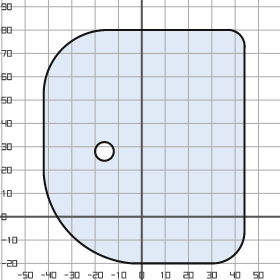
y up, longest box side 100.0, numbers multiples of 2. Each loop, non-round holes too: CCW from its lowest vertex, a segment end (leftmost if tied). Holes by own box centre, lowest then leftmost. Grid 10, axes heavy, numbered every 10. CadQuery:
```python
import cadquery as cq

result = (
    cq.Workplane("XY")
    .moveTo(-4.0, -20.0)
    .lineTo(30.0, -20.0)
    .threePointArc((40.0, -16.0), (44.0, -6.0))
    .lineTo(44.0, 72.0)
    .threePointArc((42.0, 78.0), (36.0, 80.0))
    .lineTo(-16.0, 80.0)
    .threePointArc((-34.0, 72.0), (-42.0, 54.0))
    .lineTo(-42.0, 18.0)
    .threePointArc((-30.0, -8.0), (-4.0, -20.0))
    .close()
    .moveTo(-16.0, 28.0)
    .circle(4.0)
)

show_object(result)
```